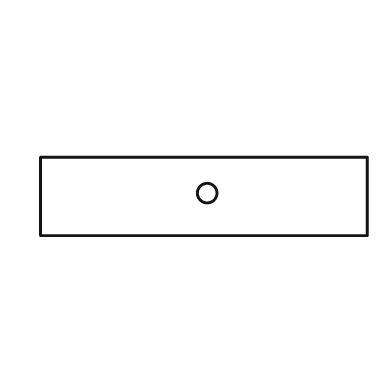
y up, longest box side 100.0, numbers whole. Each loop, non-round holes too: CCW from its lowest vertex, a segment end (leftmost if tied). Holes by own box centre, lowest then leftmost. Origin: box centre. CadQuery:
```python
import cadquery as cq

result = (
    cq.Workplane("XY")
    .moveTo(-50.0, -12.0)
    .lineTo(50.0, -12.0)
    .lineTo(50.0, 12.0)
    .lineTo(-50.0, 12.0)
    .close()
    .moveTo(1.0, 1.0)
    .circle(3.0)
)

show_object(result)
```